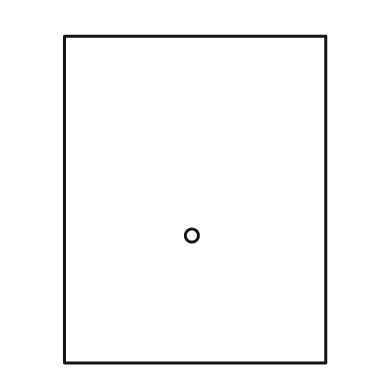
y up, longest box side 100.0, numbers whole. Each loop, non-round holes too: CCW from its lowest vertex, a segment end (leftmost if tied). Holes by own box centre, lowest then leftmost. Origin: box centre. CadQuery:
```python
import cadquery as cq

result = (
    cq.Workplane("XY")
    .moveTo(-40.0, -50.0)
    .lineTo(40.0, -50.0)
    .lineTo(40.0, 50.0)
    .lineTo(-40.0, 50.0)
    .close()
    .moveTo(-1.0, -11.0)
    .circle(2.0)
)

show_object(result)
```